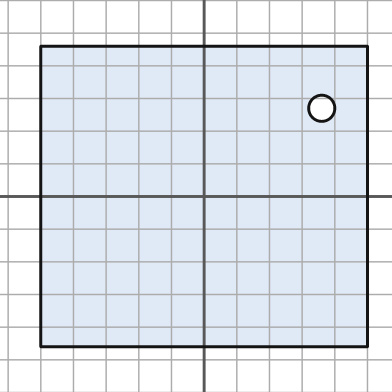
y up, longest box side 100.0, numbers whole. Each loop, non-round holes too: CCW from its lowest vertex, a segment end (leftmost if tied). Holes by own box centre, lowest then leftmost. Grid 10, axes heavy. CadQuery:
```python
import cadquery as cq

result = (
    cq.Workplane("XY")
    .moveTo(-50.0, -46.0)
    .lineTo(50.0, -46.0)
    .lineTo(50.0, 46.0)
    .lineTo(-50.0, 46.0)
    .close()
    .moveTo(36.0, 27.0)
    .circle(4.0)
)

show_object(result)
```